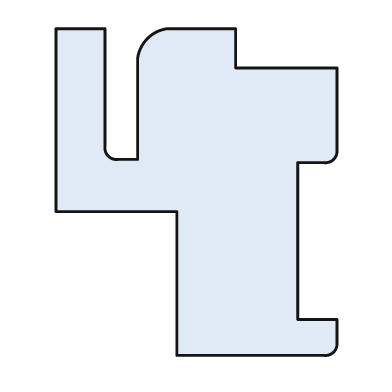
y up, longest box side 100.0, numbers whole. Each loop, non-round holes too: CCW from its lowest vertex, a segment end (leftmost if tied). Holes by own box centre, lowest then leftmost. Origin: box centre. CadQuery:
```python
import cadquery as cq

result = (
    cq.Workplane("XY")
    .moveTo(-6.0, -50.0)
    .lineTo(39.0, -50.0)
    .threePointArc((42.0, -49.0), (43.0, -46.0))
    .lineTo(43.0, -39.0)
    .lineTo(31.0, -39.0)
    .lineTo(31.0, 9.0)
    .lineTo(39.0, 9.0)
    .threePointArc((42.0, 10.0), (43.0, 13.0))
    .lineTo(43.0, 38.0)
    .lineTo(12.0, 38.0)
    .lineTo(12.0, 50.0)
    .lineTo(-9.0, 50.0)
    .threePointArc((-15.0, 47.0), (-18.0, 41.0))
    .lineTo(-18.0, 10.0)
    .lineTo(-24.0, 10.0)
    .threePointArc((-27.0, 11.0), (-28.0, 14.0))
    .lineTo(-28.0, 50.0)
    .lineTo(-43.0, 50.0)
    .lineTo(-43.0, -6.0)
    .lineTo(-6.0, -6.0)
    .close()
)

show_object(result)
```